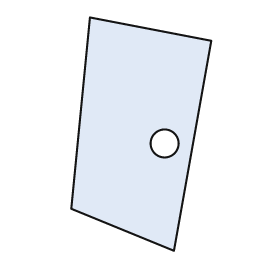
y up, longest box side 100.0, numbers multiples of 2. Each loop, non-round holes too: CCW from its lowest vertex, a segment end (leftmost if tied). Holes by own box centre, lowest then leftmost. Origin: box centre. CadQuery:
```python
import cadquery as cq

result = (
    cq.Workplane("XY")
    .moveTo(14.0, -50.0)
    .lineTo(30.0, 40.0)
    .lineTo(-22.0, 50.0)
    .lineTo(-30.0, -32.0)
    .close()
    .moveTo(10.0, -4.0)
    .circle(6.0)
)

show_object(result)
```